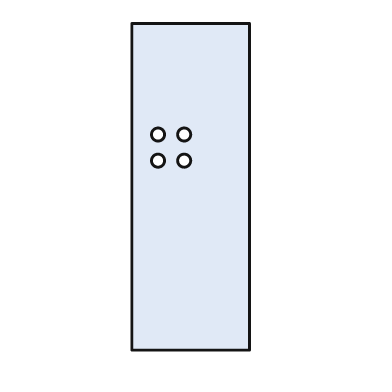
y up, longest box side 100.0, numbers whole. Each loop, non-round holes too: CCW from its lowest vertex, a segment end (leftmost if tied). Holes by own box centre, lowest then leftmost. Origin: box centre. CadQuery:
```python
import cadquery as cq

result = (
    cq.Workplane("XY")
    .moveTo(-18.0, -50.0)
    .lineTo(18.0, -50.0)
    .lineTo(18.0, 50.0)
    .lineTo(-18.0, 50.0)
    .close()
    .moveTo(-10.0, 8.0)
    .circle(2.0)
    .moveTo(-2.0, 8.0)
    .circle(2.0)
    .moveTo(-10.0, 16.0)
    .circle(2.0)
    .moveTo(-2.0, 16.0)
    .circle(2.0)
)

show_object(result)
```